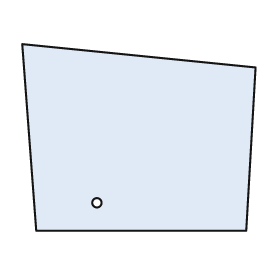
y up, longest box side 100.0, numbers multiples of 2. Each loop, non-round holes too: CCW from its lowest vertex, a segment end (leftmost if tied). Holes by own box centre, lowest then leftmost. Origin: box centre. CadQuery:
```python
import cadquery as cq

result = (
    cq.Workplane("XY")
    .moveTo(-44.0, -40.0)
    .lineTo(46.0, -40.0)
    .lineTo(50.0, 30.0)
    .lineTo(-50.0, 40.0)
    .close()
    .moveTo(-18.0, -28.0)
    .circle(2.0)
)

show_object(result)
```